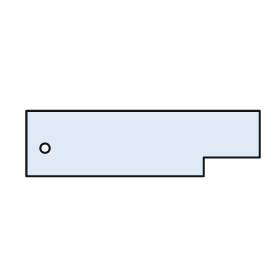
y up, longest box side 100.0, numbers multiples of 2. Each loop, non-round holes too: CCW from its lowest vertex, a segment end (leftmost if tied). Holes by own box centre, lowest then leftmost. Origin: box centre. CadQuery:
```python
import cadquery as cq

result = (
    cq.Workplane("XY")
    .moveTo(-50.0, -14.0)
    .lineTo(26.0, -14.0)
    .lineTo(26.0, -6.0)
    .lineTo(50.0, -6.0)
    .lineTo(50.0, 14.0)
    .lineTo(-50.0, 14.0)
    .close()
    .moveTo(-42.0, -2.0)
    .circle(2.0)
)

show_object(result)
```